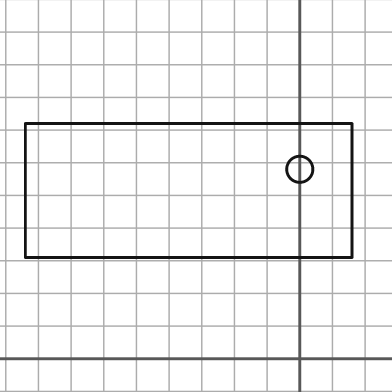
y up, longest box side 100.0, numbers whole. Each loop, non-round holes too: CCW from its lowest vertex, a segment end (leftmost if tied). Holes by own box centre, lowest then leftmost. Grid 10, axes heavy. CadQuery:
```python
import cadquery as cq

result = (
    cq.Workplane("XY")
    .moveTo(-84.0, 31.0)
    .lineTo(16.0, 31.0)
    .lineTo(16.0, 72.0)
    .lineTo(-84.0, 72.0)
    .close()
    .moveTo(0.0, 58.0)
    .circle(4.0)
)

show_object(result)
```